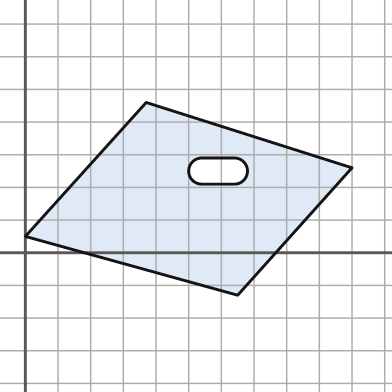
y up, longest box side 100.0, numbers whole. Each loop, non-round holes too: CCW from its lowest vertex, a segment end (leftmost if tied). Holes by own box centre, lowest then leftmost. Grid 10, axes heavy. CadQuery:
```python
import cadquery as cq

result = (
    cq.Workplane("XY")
    .moveTo(65.0, -13.0)
    .lineTo(100.0, 26.0)
    .lineTo(37.0, 46.0)
    .lineTo(0.0, 5.0)
    .close()
    .moveTo(54.0, 21.0)
    .lineTo(64.0, 21.0)
    .threePointArc((68.0, 25.0), (64.0, 29.0))
    .lineTo(54.0, 29.0)
    .threePointArc((50.0, 25.0), (54.0, 21.0))
    .close()
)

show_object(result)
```